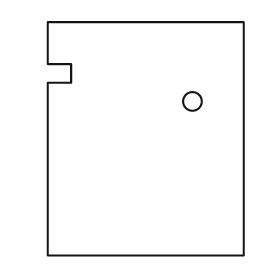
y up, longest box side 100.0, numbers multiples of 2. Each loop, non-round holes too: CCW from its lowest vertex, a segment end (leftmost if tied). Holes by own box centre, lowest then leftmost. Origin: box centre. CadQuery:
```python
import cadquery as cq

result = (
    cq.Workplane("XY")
    .moveTo(-42.0, -50.0)
    .lineTo(42.0, -50.0)
    .lineTo(42.0, 50.0)
    .lineTo(-42.0, 50.0)
    .lineTo(-42.0, 32.0)
    .lineTo(-32.0, 32.0)
    .lineTo(-32.0, 24.0)
    .lineTo(-42.0, 24.0)
    .close()
    .moveTo(20.0, 16.0)
    .circle(4.0)
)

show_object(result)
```